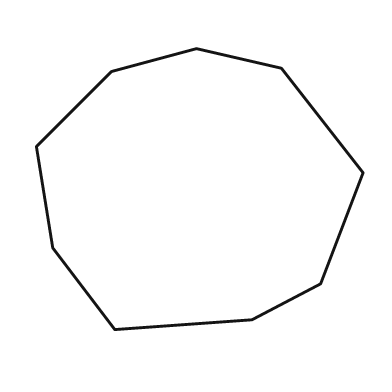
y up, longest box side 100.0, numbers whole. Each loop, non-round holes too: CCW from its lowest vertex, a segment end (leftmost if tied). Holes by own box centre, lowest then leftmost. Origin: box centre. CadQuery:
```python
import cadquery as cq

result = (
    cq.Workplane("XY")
    .moveTo(-26.0, -43.0)
    .lineTo(16.0, -40.0)
    .lineTo(37.0, -29.0)
    .lineTo(50.0, 5.0)
    .lineTo(25.0, 37.0)
    .lineTo(-1.0, 43.0)
    .lineTo(-27.0, 36.0)
    .lineTo(-50.0, 13.0)
    .lineTo(-45.0, -18.0)
    .close()
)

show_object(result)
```